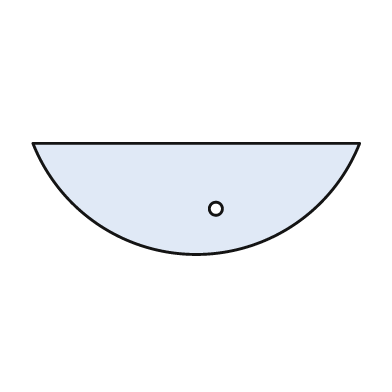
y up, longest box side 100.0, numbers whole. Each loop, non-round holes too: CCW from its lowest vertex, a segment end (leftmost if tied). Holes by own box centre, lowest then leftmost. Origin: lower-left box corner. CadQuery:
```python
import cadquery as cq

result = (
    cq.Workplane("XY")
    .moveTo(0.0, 34.0)
    .threePointArc((50.0, 0.0), (100.0, 34.0))
    .close()
    .moveTo(56.0, 14.0)
    .circle(2.0)
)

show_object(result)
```